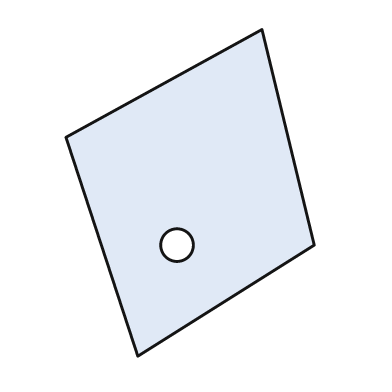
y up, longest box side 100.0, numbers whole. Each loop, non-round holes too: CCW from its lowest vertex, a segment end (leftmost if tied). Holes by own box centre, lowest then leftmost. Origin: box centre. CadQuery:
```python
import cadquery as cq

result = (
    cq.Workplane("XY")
    .moveTo(-16.0, -50.0)
    .lineTo(38.0, -16.0)
    .lineTo(22.0, 50.0)
    .lineTo(-38.0, 17.0)
    .close()
    .moveTo(-4.0, -16.0)
    .circle(5.0)
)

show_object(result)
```